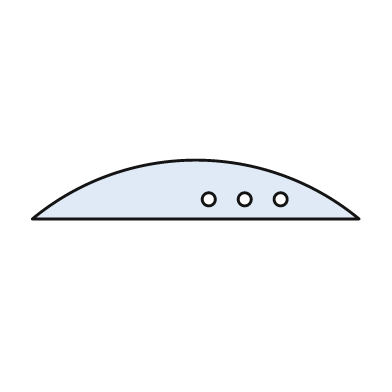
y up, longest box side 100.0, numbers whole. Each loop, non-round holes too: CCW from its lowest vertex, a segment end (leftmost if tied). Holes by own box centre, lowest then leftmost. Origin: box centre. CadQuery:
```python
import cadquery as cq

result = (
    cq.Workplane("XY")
    .moveTo(-50.0, -9.0)
    .lineTo(50.0, -9.0)
    .threePointArc((0.0, 9.0), (-50.0, -9.0))
    .close()
    .moveTo(4.0, -3.0)
    .circle(2.0)
    .moveTo(15.0, -3.0)
    .circle(2.0)
    .moveTo(26.0, -3.0)
    .circle(2.0)
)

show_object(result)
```